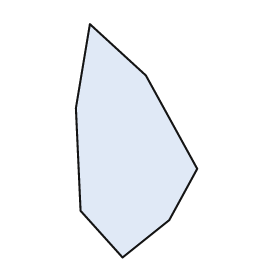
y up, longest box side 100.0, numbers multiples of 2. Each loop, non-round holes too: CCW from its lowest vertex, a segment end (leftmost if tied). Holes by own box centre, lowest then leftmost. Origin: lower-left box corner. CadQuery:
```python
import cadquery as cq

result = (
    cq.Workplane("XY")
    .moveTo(20.0, 0.0)
    .lineTo(40.0, 16.0)
    .lineTo(52.0, 38.0)
    .lineTo(30.0, 78.0)
    .lineTo(6.0, 100.0)
    .lineTo(0.0, 64.0)
    .lineTo(2.0, 20.0)
    .close()
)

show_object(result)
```